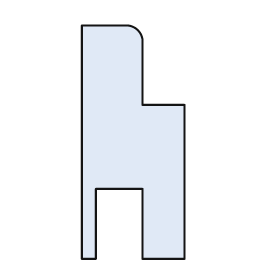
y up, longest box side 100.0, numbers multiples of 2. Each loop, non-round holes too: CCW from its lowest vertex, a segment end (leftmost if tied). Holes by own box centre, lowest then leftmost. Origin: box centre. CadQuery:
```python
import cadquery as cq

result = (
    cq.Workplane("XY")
    .moveTo(-22.0, -50.0)
    .lineTo(-16.0, -50.0)
    .lineTo(-16.0, -20.0)
    .lineTo(4.0, -20.0)
    .lineTo(4.0, -50.0)
    .lineTo(22.0, -50.0)
    .lineTo(22.0, 16.0)
    .lineTo(4.0, 16.0)
    .lineTo(4.0, 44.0)
    .threePointArc((2.0, 48.0), (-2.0, 50.0))
    .lineTo(-22.0, 50.0)
    .close()
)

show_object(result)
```